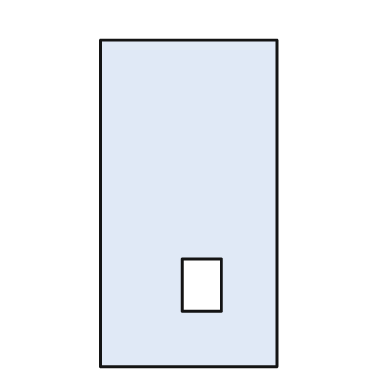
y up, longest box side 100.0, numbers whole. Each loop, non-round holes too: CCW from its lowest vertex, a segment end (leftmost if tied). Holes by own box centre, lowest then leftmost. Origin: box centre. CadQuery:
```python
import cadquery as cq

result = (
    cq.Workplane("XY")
    .moveTo(-27.0, -50.0)
    .lineTo(27.0, -50.0)
    .lineTo(27.0, 50.0)
    .lineTo(-27.0, 50.0)
    .close()
    .moveTo(-2.0, -33.0)
    .lineTo(10.0, -33.0)
    .lineTo(10.0, -17.0)
    .lineTo(-2.0, -17.0)
    .close()
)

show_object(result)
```